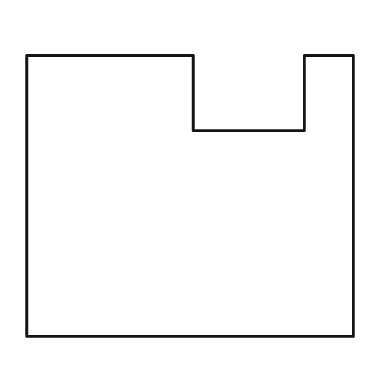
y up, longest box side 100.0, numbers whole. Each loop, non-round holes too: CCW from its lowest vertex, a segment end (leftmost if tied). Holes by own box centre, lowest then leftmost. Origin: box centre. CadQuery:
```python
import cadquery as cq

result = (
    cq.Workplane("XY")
    .moveTo(-50.0, -43.0)
    .lineTo(50.0, -43.0)
    .lineTo(50.0, 43.0)
    .lineTo(35.0, 43.0)
    .lineTo(35.0, 20.0)
    .lineTo(1.0, 20.0)
    .lineTo(1.0, 43.0)
    .lineTo(-50.0, 43.0)
    .close()
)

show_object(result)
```